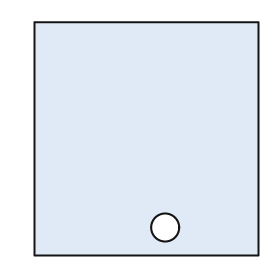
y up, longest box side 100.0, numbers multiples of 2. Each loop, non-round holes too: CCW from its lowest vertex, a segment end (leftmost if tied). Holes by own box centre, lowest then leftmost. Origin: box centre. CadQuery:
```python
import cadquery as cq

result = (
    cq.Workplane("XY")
    .moveTo(-48.0, -50.0)
    .lineTo(48.0, -50.0)
    .lineTo(48.0, 50.0)
    .lineTo(-48.0, 50.0)
    .close()
    .moveTo(8.0, -38.0)
    .circle(6.0)
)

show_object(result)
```